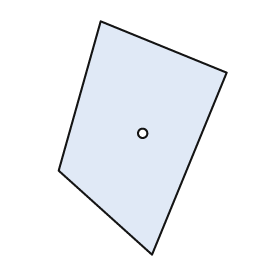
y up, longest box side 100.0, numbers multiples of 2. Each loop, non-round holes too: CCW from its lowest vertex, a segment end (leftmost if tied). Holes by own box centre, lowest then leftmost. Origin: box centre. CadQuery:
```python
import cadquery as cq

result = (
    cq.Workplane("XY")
    .moveTo(4.0, -50.0)
    .lineTo(36.0, 28.0)
    .lineTo(-18.0, 50.0)
    .lineTo(-36.0, -14.0)
    .close()
    .moveTo(0.0, 2.0)
    .circle(2.0)
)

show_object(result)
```